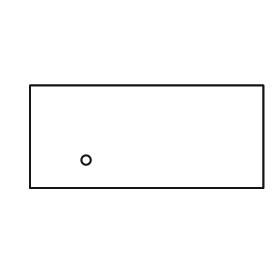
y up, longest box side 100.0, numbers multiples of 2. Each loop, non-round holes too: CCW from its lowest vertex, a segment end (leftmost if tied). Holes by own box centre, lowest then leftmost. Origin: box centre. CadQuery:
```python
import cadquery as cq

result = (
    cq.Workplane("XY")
    .moveTo(-50.0, -22.0)
    .lineTo(50.0, -22.0)
    .lineTo(50.0, 22.0)
    .lineTo(-50.0, 22.0)
    .close()
    .moveTo(-26.0, -10.0)
    .circle(2.0)
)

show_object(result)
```